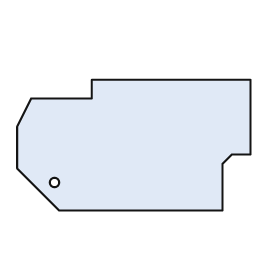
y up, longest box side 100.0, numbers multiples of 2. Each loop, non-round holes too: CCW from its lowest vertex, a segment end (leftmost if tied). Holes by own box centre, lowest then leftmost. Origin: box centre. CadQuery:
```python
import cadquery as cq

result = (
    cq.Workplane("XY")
    .moveTo(-32.0, -28.0)
    .lineTo(38.0, -28.0)
    .lineTo(38.0, -8.0)
    .lineTo(42.0, -4.0)
    .lineTo(50.0, -4.0)
    .lineTo(50.0, 28.0)
    .lineTo(-18.0, 28.0)
    .lineTo(-18.0, 20.0)
    .lineTo(-44.0, 20.0)
    .lineTo(-50.0, 8.0)
    .lineTo(-50.0, -10.0)
    .close()
    .moveTo(-34.0, -16.0)
    .circle(2.0)
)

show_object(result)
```